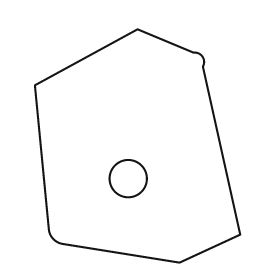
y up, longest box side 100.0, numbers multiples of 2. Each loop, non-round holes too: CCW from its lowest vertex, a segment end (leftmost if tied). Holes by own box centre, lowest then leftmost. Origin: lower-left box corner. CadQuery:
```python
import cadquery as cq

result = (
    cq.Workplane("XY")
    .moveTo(62.0, 0.0)
    .lineTo(88.0, 12.0)
    .lineTo(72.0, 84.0)
    .threePointArc((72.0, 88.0), (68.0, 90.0))
    .lineTo(44.0, 100.0)
    .lineTo(0.0, 76.0)
    .lineTo(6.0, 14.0)
    .threePointArc((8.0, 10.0), (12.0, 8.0))
    .close()
    .moveTo(40.0, 36.0)
    .circle(8.0)
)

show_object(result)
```